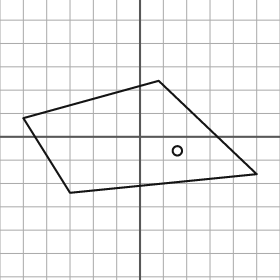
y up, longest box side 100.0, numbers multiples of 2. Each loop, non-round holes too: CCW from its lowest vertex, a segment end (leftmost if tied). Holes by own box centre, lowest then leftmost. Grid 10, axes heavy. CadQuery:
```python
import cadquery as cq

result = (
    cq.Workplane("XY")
    .moveTo(-30.0, -24.0)
    .lineTo(50.0, -16.0)
    .lineTo(8.0, 24.0)
    .lineTo(-50.0, 8.0)
    .close()
    .moveTo(16.0, -6.0)
    .circle(2.0)
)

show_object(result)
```